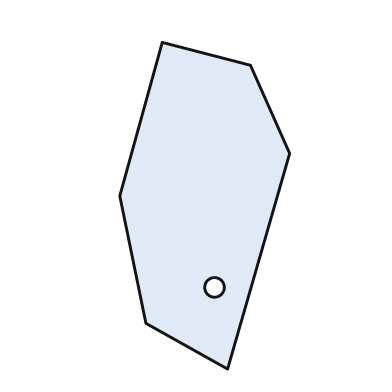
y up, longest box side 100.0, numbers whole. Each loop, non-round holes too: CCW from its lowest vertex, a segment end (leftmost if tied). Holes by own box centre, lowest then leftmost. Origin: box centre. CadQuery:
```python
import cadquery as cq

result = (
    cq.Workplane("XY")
    .moveTo(7.0, -50.0)
    .lineTo(26.0, 16.0)
    .lineTo(14.0, 43.0)
    .lineTo(-13.0, 50.0)
    .lineTo(-26.0, 3.0)
    .lineTo(-18.0, -36.0)
    .close()
    .moveTo(3.0, -25.0)
    .circle(3.0)
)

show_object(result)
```